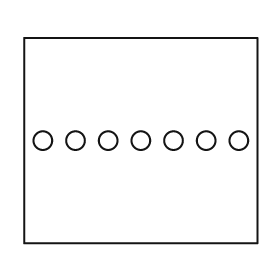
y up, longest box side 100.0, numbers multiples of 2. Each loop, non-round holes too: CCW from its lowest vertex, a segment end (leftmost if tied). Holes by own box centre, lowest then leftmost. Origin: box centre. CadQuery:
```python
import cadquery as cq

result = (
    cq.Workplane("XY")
    .moveTo(-50.0, -44.0)
    .lineTo(50.0, -44.0)
    .lineTo(50.0, 44.0)
    .lineTo(-50.0, 44.0)
    .close()
    .moveTo(-42.0, 0.0)
    .circle(4.0)
    .moveTo(-28.0, 0.0)
    .circle(4.0)
    .moveTo(-14.0, 0.0)
    .circle(4.0)
    .moveTo(0.0, 0.0)
    .circle(4.0)
    .moveTo(14.0, 0.0)
    .circle(4.0)
    .moveTo(28.0, 0.0)
    .circle(4.0)
    .moveTo(42.0, 0.0)
    .circle(4.0)
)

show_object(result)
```